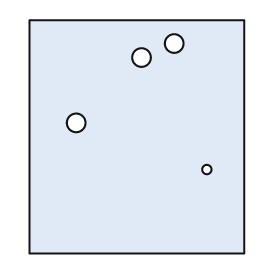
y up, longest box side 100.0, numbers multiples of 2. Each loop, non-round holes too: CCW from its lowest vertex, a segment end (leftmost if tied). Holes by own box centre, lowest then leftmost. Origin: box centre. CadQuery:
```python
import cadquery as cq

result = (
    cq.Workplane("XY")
    .moveTo(-46.0, -50.0)
    .lineTo(46.0, -50.0)
    .lineTo(46.0, 50.0)
    .lineTo(-46.0, 50.0)
    .close()
    .moveTo(30.0, -14.0)
    .circle(2.0)
    .moveTo(-26.0, 6.0)
    .circle(4.0)
    .moveTo(2.0, 34.0)
    .circle(4.0)
    .moveTo(16.0, 40.0)
    .circle(4.0)
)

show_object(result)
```